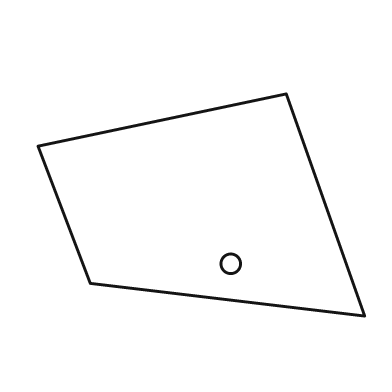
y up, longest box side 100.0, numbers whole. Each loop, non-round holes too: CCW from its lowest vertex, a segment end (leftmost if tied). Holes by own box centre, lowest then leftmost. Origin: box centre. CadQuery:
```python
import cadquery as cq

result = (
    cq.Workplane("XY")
    .moveTo(50.0, -34.0)
    .lineTo(26.0, 34.0)
    .lineTo(-50.0, 18.0)
    .lineTo(-34.0, -24.0)
    .close()
    .moveTo(9.0, -18.0)
    .circle(3.0)
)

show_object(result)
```